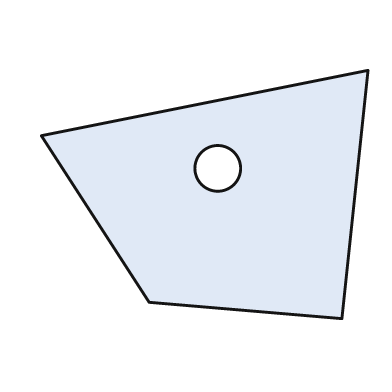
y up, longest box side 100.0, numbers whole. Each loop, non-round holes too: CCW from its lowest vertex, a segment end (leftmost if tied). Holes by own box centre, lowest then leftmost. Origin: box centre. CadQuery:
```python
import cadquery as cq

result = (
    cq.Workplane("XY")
    .moveTo(42.0, -38.0)
    .lineTo(50.0, 38.0)
    .lineTo(-50.0, 18.0)
    .lineTo(-17.0, -33.0)
    .close()
    .moveTo(4.0, 8.0)
    .circle(7.0)
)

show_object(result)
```